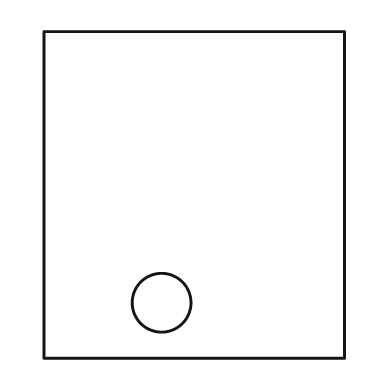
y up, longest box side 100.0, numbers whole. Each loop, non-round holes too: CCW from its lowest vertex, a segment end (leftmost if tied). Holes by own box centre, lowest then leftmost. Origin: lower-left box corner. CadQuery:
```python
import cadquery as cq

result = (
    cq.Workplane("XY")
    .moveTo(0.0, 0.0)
    .lineTo(92.0, 0.0)
    .lineTo(92.0, 100.0)
    .lineTo(0.0, 100.0)
    .close()
    .moveTo(36.0, 17.0)
    .circle(9.0)
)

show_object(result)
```